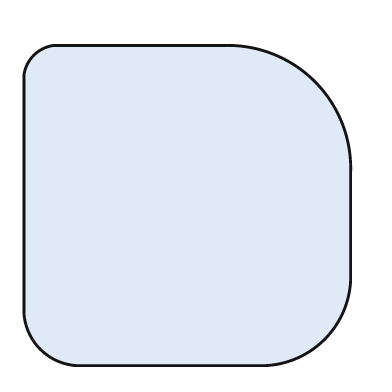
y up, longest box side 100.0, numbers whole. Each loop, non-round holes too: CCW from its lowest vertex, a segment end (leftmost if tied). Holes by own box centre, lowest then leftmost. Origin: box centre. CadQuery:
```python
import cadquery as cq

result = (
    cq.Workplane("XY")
    .moveTo(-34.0, -49.0)
    .lineTo(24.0, -49.0)
    .threePointArc((42.0, -41.0), (50.0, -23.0))
    .lineTo(50.0, 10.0)
    .threePointArc((39.0, 38.0), (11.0, 49.0))
    .lineTo(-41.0, 49.0)
    .threePointArc((-47.0, 46.0), (-50.0, 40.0))
    .lineTo(-50.0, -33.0)
    .threePointArc((-45.0, -44.0), (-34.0, -49.0))
    .close()
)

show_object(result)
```